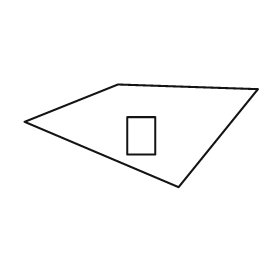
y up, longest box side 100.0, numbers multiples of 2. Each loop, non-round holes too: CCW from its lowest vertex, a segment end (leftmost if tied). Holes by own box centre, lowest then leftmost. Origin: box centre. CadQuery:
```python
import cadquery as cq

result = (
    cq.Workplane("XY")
    .moveTo(16.0, -22.0)
    .lineTo(50.0, 20.0)
    .lineTo(-10.0, 22.0)
    .lineTo(-50.0, 6.0)
    .close()
    .moveTo(-6.0, -8.0)
    .lineTo(6.0, -8.0)
    .lineTo(6.0, 8.0)
    .lineTo(-6.0, 8.0)
    .close()
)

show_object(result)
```